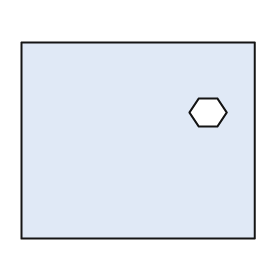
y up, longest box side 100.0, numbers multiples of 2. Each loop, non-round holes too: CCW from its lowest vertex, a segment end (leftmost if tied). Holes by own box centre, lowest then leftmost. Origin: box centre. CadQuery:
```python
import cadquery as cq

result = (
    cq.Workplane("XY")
    .moveTo(-50.0, -42.0)
    .lineTo(50.0, -42.0)
    .lineTo(50.0, 42.0)
    .lineTo(-50.0, 42.0)
    .close()
    .moveTo(26.0, 6.0)
    .lineTo(34.0, 6.0)
    .lineTo(38.0, 12.0)
    .lineTo(34.0, 18.0)
    .lineTo(26.0, 18.0)
    .lineTo(22.0, 12.0)
    .close()
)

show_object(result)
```